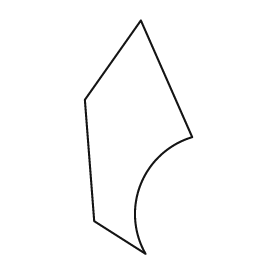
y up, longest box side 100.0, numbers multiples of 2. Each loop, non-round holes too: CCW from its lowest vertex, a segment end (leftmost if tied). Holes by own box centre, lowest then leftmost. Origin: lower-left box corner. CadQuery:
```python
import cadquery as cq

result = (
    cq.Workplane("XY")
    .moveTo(26.0, 0.0)
    .threePointArc((24.0, 30.0), (46.0, 50.0))
    .lineTo(24.0, 100.0)
    .lineTo(0.0, 66.0)
    .lineTo(4.0, 14.0)
    .close()
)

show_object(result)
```